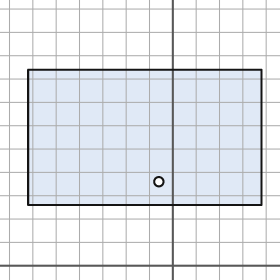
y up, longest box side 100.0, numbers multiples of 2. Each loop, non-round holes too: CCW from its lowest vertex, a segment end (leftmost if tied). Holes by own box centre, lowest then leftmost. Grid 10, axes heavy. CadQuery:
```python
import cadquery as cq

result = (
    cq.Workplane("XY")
    .moveTo(-62.0, 26.0)
    .lineTo(38.0, 26.0)
    .lineTo(38.0, 84.0)
    .lineTo(-62.0, 84.0)
    .close()
    .moveTo(-6.0, 36.0)
    .circle(2.0)
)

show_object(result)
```